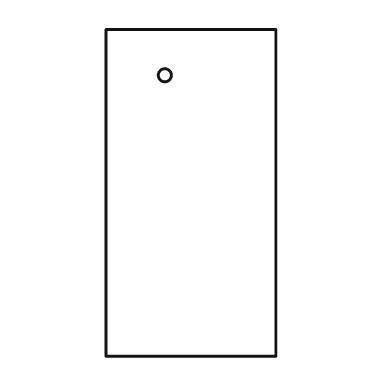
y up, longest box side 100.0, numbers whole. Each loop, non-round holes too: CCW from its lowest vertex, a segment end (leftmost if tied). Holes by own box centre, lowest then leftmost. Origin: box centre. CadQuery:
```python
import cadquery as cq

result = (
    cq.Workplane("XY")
    .moveTo(-26.0, -50.0)
    .lineTo(26.0, -50.0)
    .lineTo(26.0, 50.0)
    .lineTo(-26.0, 50.0)
    .close()
    .moveTo(-8.0, 36.0)
    .circle(2.0)
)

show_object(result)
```